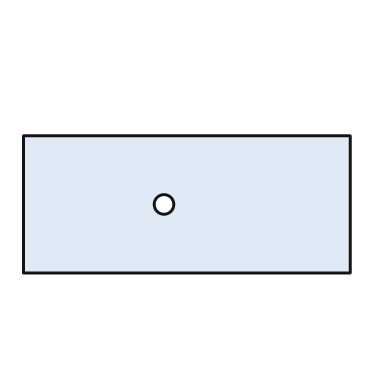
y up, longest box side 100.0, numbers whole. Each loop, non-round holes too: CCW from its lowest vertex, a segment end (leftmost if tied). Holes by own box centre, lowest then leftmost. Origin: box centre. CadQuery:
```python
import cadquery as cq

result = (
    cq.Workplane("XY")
    .moveTo(-50.0, -21.0)
    .lineTo(50.0, -21.0)
    .lineTo(50.0, 21.0)
    .lineTo(-50.0, 21.0)
    .close()
    .moveTo(-7.0, 0.0)
    .circle(3.0)
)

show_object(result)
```